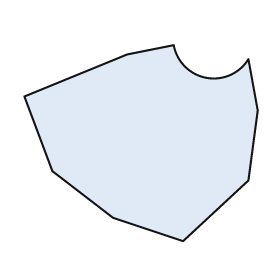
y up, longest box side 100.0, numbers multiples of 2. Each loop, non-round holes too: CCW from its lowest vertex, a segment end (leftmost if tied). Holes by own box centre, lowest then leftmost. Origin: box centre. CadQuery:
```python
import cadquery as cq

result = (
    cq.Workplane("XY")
    .moveTo(18.0, -42.0)
    .lineTo(46.0, -16.0)
    .lineTo(50.0, 14.0)
    .lineTo(46.0, 36.0)
    .threePointArc((28.0, 28.0), (14.0, 42.0))
    .lineTo(-6.0, 38.0)
    .lineTo(-50.0, 20.0)
    .lineTo(-38.0, -12.0)
    .lineTo(-12.0, -32.0)
    .close()
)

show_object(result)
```